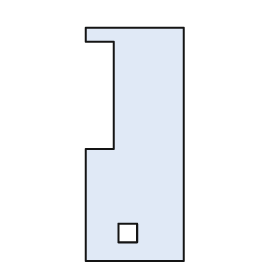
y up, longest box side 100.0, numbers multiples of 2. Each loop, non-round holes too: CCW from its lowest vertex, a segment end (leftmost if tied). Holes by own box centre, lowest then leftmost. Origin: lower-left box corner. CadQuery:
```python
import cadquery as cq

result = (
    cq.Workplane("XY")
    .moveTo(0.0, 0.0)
    .lineTo(42.0, 0.0)
    .lineTo(42.0, 100.0)
    .lineTo(0.0, 100.0)
    .lineTo(0.0, 94.0)
    .lineTo(12.0, 94.0)
    .lineTo(12.0, 48.0)
    .lineTo(0.0, 48.0)
    .close()
    .moveTo(14.0, 8.0)
    .lineTo(22.0, 8.0)
    .lineTo(22.0, 16.0)
    .lineTo(14.0, 16.0)
    .close()
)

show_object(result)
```